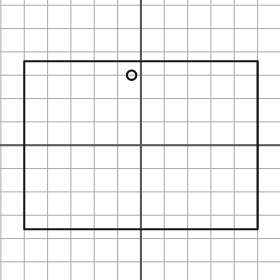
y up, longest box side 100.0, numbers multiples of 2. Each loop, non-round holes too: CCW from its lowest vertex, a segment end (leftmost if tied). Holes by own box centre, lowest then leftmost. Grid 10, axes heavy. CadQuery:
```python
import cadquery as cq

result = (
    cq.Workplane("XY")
    .moveTo(-50.0, -36.0)
    .lineTo(50.0, -36.0)
    .lineTo(50.0, 36.0)
    .lineTo(-50.0, 36.0)
    .close()
    .moveTo(-4.0, 30.0)
    .circle(2.0)
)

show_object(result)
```